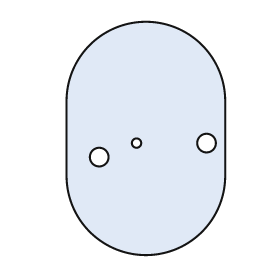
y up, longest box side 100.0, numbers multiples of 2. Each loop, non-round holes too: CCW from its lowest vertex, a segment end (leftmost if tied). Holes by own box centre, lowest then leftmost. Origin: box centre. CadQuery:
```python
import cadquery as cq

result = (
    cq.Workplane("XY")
    .moveTo(-34.0, -16.0)
    .threePointArc((0.0, -50.0), (34.0, -16.0))
    .lineTo(34.0, 16.0)
    .threePointArc((0.0, 50.0), (-34.0, 16.0))
    .close()
    .moveTo(-20.0, -8.0)
    .circle(4.0)
    .moveTo(-4.0, -2.0)
    .circle(2.0)
    .moveTo(26.0, -2.0)
    .circle(4.0)
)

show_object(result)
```